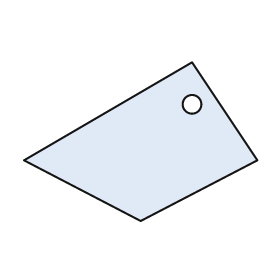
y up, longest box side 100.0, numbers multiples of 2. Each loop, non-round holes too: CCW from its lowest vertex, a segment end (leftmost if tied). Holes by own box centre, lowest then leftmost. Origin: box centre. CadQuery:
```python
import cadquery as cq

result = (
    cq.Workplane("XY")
    .moveTo(0.0, -34.0)
    .lineTo(50.0, -8.0)
    .lineTo(22.0, 34.0)
    .lineTo(-50.0, -8.0)
    .close()
    .moveTo(22.0, 16.0)
    .circle(4.0)
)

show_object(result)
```